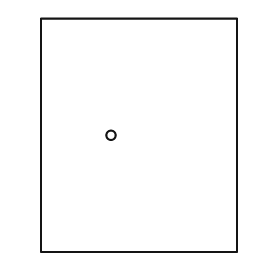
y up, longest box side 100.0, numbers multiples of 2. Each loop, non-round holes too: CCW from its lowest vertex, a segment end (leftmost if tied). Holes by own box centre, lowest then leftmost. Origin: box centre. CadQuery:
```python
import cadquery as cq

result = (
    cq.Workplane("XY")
    .moveTo(-42.0, -50.0)
    .lineTo(42.0, -50.0)
    .lineTo(42.0, 50.0)
    .lineTo(-42.0, 50.0)
    .close()
    .moveTo(-12.0, 0.0)
    .circle(2.0)
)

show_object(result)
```